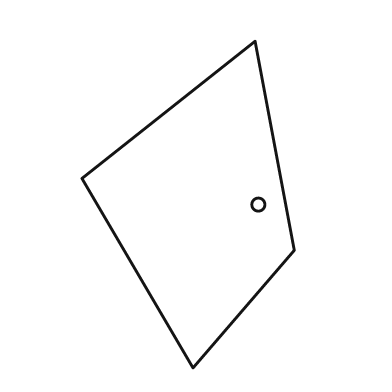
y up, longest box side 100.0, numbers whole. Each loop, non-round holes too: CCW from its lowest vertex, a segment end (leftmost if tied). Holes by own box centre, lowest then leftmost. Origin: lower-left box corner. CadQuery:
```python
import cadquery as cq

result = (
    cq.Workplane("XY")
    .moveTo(34.0, 0.0)
    .lineTo(65.0, 36.0)
    .lineTo(53.0, 100.0)
    .lineTo(0.0, 58.0)
    .close()
    .moveTo(54.0, 50.0)
    .circle(2.0)
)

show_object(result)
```